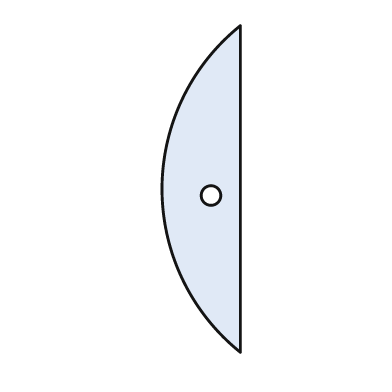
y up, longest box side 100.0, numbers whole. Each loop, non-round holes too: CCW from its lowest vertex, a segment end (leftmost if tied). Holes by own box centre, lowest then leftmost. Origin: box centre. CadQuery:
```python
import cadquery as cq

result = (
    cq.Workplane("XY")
    .moveTo(12.0, -50.0)
    .lineTo(12.0, 50.0)
    .threePointArc((-12.0, 0.0), (12.0, -50.0))
    .close()
    .moveTo(3.0, -2.0)
    .circle(3.0)
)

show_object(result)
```